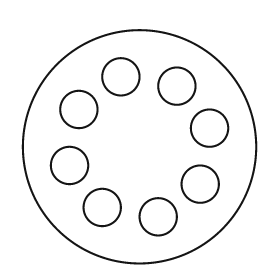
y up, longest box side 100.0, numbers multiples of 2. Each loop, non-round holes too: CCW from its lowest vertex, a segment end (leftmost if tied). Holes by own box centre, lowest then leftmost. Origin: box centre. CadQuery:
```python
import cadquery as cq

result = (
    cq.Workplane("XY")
    .moveTo(0.0, 0.0)
    .circle(50.0)
    .moveTo(8.0, -30.0)
    .circle(8.0)
    .moveTo(-16.0, -26.0)
    .circle(8.0)
    .moveTo(26.0, -16.0)
    .circle(8.0)
    .moveTo(-30.0, -8.0)
    .circle(8.0)
    .moveTo(30.0, 8.0)
    .circle(8.0)
    .moveTo(-26.0, 16.0)
    .circle(8.0)
    .moveTo(16.0, 26.0)
    .circle(8.0)
    .moveTo(-8.0, 30.0)
    .circle(8.0)
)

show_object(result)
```